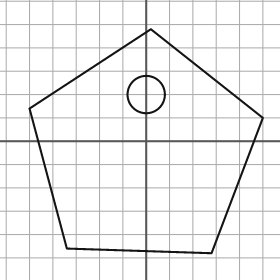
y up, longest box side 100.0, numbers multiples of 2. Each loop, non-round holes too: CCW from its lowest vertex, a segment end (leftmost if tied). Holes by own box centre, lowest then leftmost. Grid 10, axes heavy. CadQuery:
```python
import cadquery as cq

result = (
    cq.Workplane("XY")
    .moveTo(28.0, -48.0)
    .lineTo(50.0, 10.0)
    .lineTo(2.0, 48.0)
    .lineTo(-50.0, 14.0)
    .lineTo(-34.0, -46.0)
    .close()
    .moveTo(0.0, 20.0)
    .circle(8.0)
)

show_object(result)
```